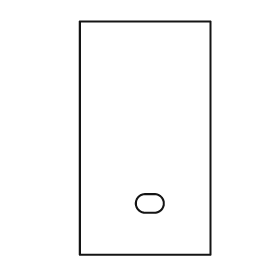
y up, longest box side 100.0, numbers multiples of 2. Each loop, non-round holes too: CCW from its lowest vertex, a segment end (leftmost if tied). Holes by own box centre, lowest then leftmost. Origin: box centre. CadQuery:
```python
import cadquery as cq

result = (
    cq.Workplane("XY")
    .moveTo(-28.0, -50.0)
    .lineTo(28.0, -50.0)
    .lineTo(28.0, 50.0)
    .lineTo(-28.0, 50.0)
    .close()
    .moveTo(0.0, -32.0)
    .lineTo(4.0, -32.0)
    .threePointArc((8.0, -28.0), (4.0, -24.0))
    .lineTo(0.0, -24.0)
    .threePointArc((-4.0, -28.0), (0.0, -32.0))
    .close()
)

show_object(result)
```